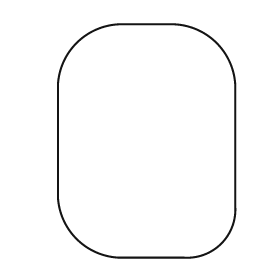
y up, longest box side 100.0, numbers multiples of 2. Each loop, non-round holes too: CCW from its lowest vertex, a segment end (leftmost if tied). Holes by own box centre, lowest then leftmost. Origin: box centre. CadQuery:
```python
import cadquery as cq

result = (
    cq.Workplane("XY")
    .moveTo(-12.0, -50.0)
    .lineTo(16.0, -50.0)
    .threePointArc((32.0, -44.0), (38.0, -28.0))
    .lineTo(38.0, 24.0)
    .threePointArc((30.0, 42.0), (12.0, 50.0))
    .lineTo(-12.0, 50.0)
    .threePointArc((-30.0, 42.0), (-38.0, 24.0))
    .lineTo(-38.0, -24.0)
    .threePointArc((-30.0, -42.0), (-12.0, -50.0))
    .close()
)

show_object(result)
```